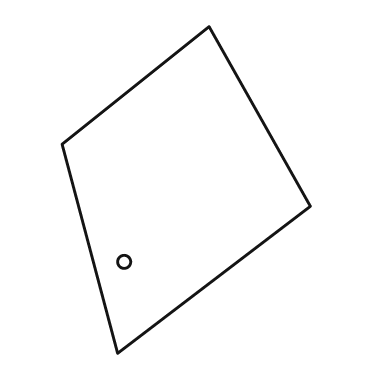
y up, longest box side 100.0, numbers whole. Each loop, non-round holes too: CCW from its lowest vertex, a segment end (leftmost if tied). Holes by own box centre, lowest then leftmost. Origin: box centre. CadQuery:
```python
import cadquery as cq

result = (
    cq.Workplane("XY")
    .moveTo(-21.0, -50.0)
    .lineTo(38.0, -5.0)
    .lineTo(7.0, 50.0)
    .lineTo(-38.0, 14.0)
    .close()
    .moveTo(-19.0, -22.0)
    .circle(2.0)
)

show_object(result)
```